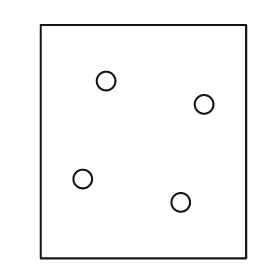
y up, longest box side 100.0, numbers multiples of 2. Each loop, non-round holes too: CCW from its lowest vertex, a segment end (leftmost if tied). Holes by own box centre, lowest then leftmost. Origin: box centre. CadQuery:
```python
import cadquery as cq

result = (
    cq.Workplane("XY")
    .moveTo(-44.0, -50.0)
    .lineTo(44.0, -50.0)
    .lineTo(44.0, 50.0)
    .lineTo(-44.0, 50.0)
    .close()
    .moveTo(16.0, -26.0)
    .circle(4.0)
    .moveTo(-26.0, -16.0)
    .circle(4.0)
    .moveTo(26.0, 16.0)
    .circle(4.0)
    .moveTo(-16.0, 26.0)
    .circle(4.0)
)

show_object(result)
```